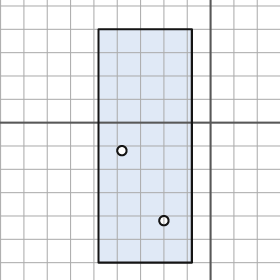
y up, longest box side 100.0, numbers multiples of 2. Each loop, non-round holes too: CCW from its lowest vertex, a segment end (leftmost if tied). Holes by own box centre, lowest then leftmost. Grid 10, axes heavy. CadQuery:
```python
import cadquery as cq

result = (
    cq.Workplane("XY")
    .moveTo(-48.0, -60.0)
    .lineTo(-8.0, -60.0)
    .lineTo(-8.0, 40.0)
    .lineTo(-48.0, 40.0)
    .close()
    .moveTo(-20.0, -42.0)
    .circle(2.0)
    .moveTo(-38.0, -12.0)
    .circle(2.0)
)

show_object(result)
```